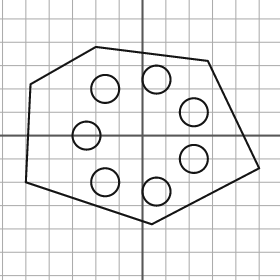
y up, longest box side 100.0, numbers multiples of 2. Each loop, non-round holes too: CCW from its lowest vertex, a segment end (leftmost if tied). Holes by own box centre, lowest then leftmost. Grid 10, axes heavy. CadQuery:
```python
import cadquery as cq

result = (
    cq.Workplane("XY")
    .moveTo(4.0, -38.0)
    .lineTo(50.0, -14.0)
    .lineTo(28.0, 32.0)
    .lineTo(-20.0, 38.0)
    .lineTo(-48.0, 22.0)
    .lineTo(-50.0, -20.0)
    .close()
    .moveTo(6.0, -24.0)
    .circle(6.0)
    .moveTo(-16.0, -20.0)
    .circle(6.0)
    .moveTo(22.0, -10.0)
    .circle(6.0)
    .moveTo(-24.0, 0.0)
    .circle(6.0)
    .moveTo(22.0, 10.0)
    .circle(6.0)
    .moveTo(-16.0, 20.0)
    .circle(6.0)
    .moveTo(6.0, 24.0)
    .circle(6.0)
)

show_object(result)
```